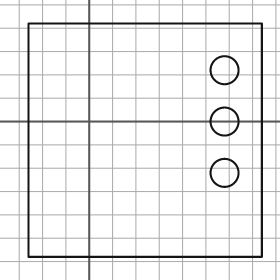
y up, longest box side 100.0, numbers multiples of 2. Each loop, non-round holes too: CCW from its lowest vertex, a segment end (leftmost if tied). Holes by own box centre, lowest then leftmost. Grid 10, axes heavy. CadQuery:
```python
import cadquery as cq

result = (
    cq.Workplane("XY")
    .moveTo(-26.0, -58.0)
    .lineTo(74.0, -58.0)
    .lineTo(74.0, 42.0)
    .lineTo(-26.0, 42.0)
    .close()
    .moveTo(58.0, -22.0)
    .circle(6.0)
    .moveTo(58.0, 0.0)
    .circle(6.0)
    .moveTo(58.0, 22.0)
    .circle(6.0)
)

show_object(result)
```